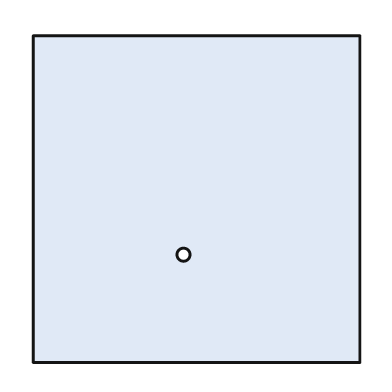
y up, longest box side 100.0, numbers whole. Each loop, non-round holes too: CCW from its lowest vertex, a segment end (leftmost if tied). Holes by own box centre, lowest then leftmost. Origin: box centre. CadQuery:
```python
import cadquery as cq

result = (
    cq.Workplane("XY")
    .moveTo(-50.0, -50.0)
    .lineTo(50.0, -50.0)
    .lineTo(50.0, 50.0)
    .lineTo(-50.0, 50.0)
    .close()
    .moveTo(-4.0, -17.0)
    .circle(2.0)
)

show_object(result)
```